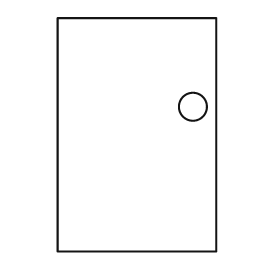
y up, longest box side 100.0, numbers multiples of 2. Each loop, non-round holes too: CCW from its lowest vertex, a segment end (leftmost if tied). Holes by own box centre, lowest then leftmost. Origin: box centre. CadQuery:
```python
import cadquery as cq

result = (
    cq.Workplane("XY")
    .moveTo(-34.0, -50.0)
    .lineTo(34.0, -50.0)
    .lineTo(34.0, 50.0)
    .lineTo(-34.0, 50.0)
    .close()
    .moveTo(24.0, 12.0)
    .circle(6.0)
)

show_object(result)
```